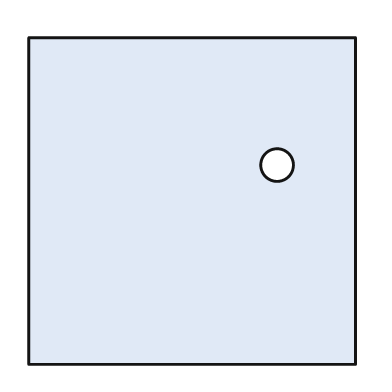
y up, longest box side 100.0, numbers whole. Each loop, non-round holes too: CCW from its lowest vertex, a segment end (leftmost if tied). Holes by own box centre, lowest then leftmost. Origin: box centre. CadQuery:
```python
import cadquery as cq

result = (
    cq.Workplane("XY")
    .moveTo(-50.0, -50.0)
    .lineTo(50.0, -50.0)
    .lineTo(50.0, 50.0)
    .lineTo(-50.0, 50.0)
    .close()
    .moveTo(26.0, 11.0)
    .circle(5.0)
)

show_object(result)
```